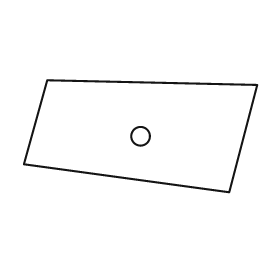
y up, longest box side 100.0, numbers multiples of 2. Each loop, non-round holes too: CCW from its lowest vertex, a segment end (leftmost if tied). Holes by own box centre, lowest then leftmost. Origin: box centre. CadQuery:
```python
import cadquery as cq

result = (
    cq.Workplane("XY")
    .moveTo(38.0, -24.0)
    .lineTo(50.0, 22.0)
    .lineTo(-40.0, 24.0)
    .lineTo(-50.0, -12.0)
    .close()
    .moveTo(0.0, 0.0)
    .circle(4.0)
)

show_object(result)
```